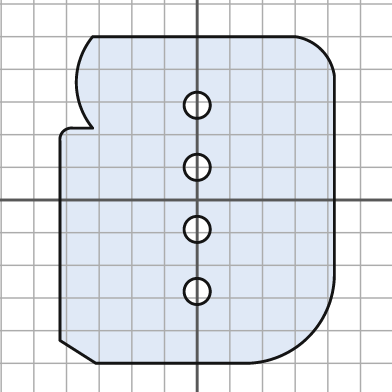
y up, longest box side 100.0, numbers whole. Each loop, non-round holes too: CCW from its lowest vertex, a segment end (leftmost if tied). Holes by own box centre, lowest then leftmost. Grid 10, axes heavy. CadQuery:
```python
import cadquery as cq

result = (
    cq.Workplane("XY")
    .moveTo(-31.0, -50.0)
    .lineTo(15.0, -50.0)
    .threePointArc((34.0, -42.0), (42.0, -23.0))
    .lineTo(42.0, 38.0)
    .threePointArc((38.0, 46.0), (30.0, 50.0))
    .lineTo(-32.0, 50.0)
    .threePointArc((-37.0, 36.0), (-32.0, 22.0))
    .lineTo(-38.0, 22.0)
    .threePointArc((-41.0, 21.0), (-42.0, 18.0))
    .lineTo(-42.0, -43.0)
    .close()
    .moveTo(0.0, -28.0)
    .circle(4.0)
    .moveTo(0.0, -9.0)
    .circle(4.0)
    .moveTo(0.0, 10.0)
    .circle(4.0)
    .moveTo(0.0, 29.0)
    .circle(4.0)
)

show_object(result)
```